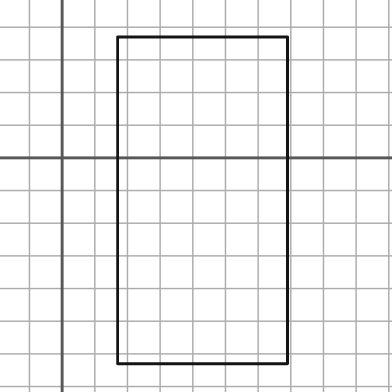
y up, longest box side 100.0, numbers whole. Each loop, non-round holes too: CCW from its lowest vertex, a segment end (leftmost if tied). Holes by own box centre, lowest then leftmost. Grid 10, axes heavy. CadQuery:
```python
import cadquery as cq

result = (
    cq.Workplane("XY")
    .moveTo(17.0, -63.0)
    .lineTo(69.0, -63.0)
    .lineTo(69.0, 37.0)
    .lineTo(17.0, 37.0)
    .close()
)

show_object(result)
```